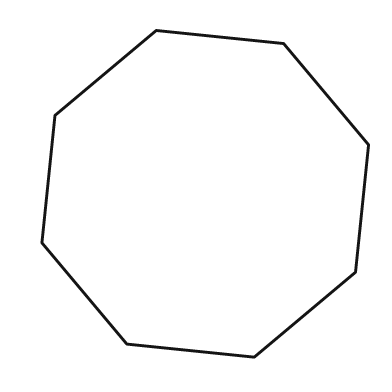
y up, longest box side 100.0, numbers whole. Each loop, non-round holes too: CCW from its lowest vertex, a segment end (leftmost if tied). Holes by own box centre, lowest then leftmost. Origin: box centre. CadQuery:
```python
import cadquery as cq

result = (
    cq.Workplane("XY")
    .moveTo(15.0, -50.0)
    .lineTo(46.0, -24.0)
    .lineTo(50.0, 15.0)
    .lineTo(24.0, 46.0)
    .lineTo(-15.0, 50.0)
    .lineTo(-46.0, 24.0)
    .lineTo(-50.0, -15.0)
    .lineTo(-24.0, -46.0)
    .close()
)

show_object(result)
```